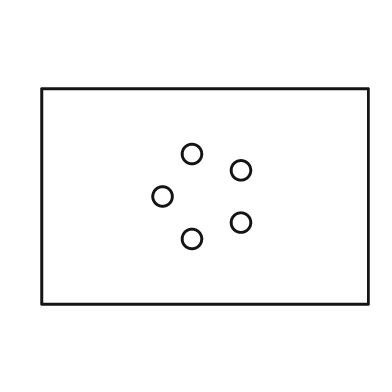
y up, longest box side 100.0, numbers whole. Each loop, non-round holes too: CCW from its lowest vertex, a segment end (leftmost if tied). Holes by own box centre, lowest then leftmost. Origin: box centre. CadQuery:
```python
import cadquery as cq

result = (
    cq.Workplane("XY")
    .moveTo(-50.0, -33.0)
    .lineTo(50.0, -33.0)
    .lineTo(50.0, 33.0)
    .lineTo(-50.0, 33.0)
    .close()
    .moveTo(-4.0, -13.0)
    .circle(3.0)
    .moveTo(11.0, -8.0)
    .circle(3.0)
    .moveTo(-13.0, 0.0)
    .circle(3.0)
    .moveTo(11.0, 8.0)
    .circle(3.0)
    .moveTo(-4.0, 13.0)
    .circle(3.0)
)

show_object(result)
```